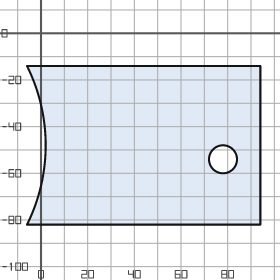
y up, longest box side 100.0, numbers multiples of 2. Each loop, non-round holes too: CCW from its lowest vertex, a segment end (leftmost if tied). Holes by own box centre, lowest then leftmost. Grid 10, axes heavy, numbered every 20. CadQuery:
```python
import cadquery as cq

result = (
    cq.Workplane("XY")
    .moveTo(-6.0, -82.0)
    .lineTo(94.0, -82.0)
    .lineTo(94.0, -14.0)
    .lineTo(-6.0, -14.0)
    .threePointArc((2.0, -48.0), (-6.0, -82.0))
    .close()
    .moveTo(78.0, -54.0)
    .circle(6.0)
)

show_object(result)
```